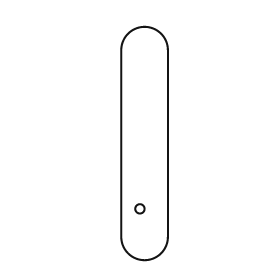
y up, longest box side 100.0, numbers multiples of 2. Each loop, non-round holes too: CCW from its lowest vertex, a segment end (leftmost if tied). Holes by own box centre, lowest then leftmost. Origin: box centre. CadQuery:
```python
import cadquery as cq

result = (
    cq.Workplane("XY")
    .moveTo(-10.0, -40.0)
    .threePointArc((0.0, -50.0), (10.0, -40.0))
    .lineTo(10.0, 40.0)
    .threePointArc((0.0, 50.0), (-10.0, 40.0))
    .close()
    .moveTo(-2.0, -28.0)
    .circle(2.0)
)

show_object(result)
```